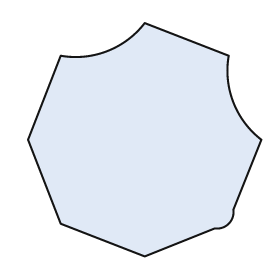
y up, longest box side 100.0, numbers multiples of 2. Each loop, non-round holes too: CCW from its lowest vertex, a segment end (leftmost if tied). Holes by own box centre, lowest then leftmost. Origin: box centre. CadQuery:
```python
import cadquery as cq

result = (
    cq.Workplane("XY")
    .moveTo(0.0, -50.0)
    .lineTo(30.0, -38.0)
    .threePointArc((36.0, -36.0), (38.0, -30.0))
    .lineTo(50.0, 0.0)
    .threePointArc((38.0, 16.0), (36.0, 36.0))
    .lineTo(0.0, 50.0)
    .threePointArc((-16.0, 38.0), (-36.0, 36.0))
    .lineTo(-50.0, 0.0)
    .lineTo(-36.0, -36.0)
    .close()
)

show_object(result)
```